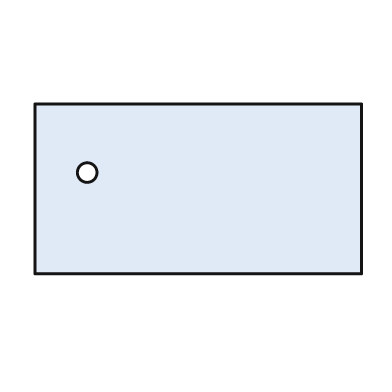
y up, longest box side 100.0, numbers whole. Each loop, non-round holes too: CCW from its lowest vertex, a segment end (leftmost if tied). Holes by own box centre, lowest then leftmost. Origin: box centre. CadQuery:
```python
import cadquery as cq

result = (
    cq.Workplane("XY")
    .moveTo(-50.0, -26.0)
    .lineTo(50.0, -26.0)
    .lineTo(50.0, 26.0)
    .lineTo(-50.0, 26.0)
    .close()
    .moveTo(-34.0, 5.0)
    .circle(3.0)
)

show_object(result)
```